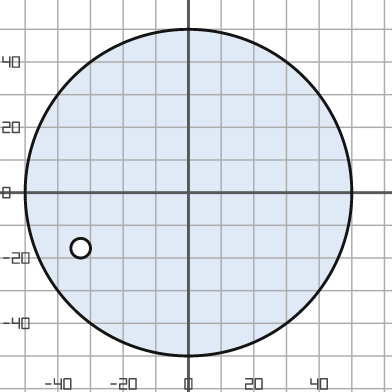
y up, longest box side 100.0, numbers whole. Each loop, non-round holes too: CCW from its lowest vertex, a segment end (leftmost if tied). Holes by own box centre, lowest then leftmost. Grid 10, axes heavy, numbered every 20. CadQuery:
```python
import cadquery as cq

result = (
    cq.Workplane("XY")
    .moveTo(0.0, 0.0)
    .circle(50.0)
    .moveTo(-33.0, -17.0)
    .circle(3.0)
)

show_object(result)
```